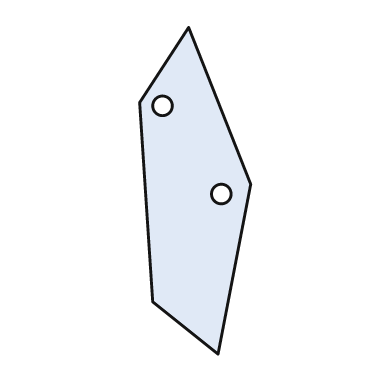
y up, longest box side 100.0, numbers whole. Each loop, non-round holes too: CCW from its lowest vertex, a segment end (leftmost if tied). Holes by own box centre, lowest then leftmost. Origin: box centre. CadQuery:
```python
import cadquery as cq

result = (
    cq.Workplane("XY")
    .moveTo(7.0, -50.0)
    .lineTo(17.0, 2.0)
    .lineTo(-2.0, 50.0)
    .lineTo(-17.0, 27.0)
    .lineTo(-13.0, -34.0)
    .close()
    .moveTo(8.0, -1.0)
    .circle(3.0)
    .moveTo(-10.0, 26.0)
    .circle(3.0)
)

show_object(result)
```